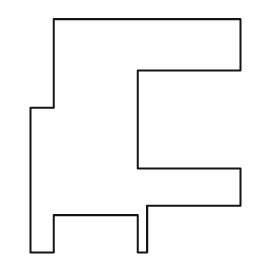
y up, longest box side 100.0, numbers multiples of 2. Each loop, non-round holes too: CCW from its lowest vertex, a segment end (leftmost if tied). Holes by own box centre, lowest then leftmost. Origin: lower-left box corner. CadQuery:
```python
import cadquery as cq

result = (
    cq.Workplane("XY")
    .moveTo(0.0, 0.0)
    .lineTo(10.0, 0.0)
    .lineTo(10.0, 16.0)
    .lineTo(46.0, 16.0)
    .lineTo(46.0, 0.0)
    .lineTo(50.0, 0.0)
    .lineTo(50.0, 20.0)
    .lineTo(90.0, 20.0)
    .lineTo(90.0, 36.0)
    .lineTo(46.0, 36.0)
    .lineTo(46.0, 78.0)
    .lineTo(90.0, 78.0)
    .lineTo(90.0, 100.0)
    .lineTo(10.0, 100.0)
    .lineTo(10.0, 62.0)
    .lineTo(0.0, 62.0)
    .close()
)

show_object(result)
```